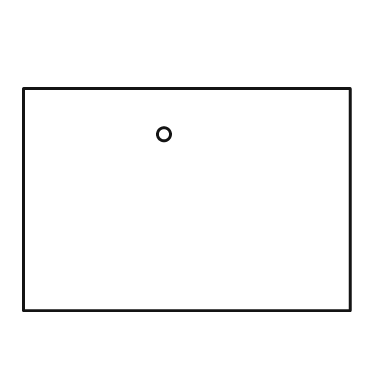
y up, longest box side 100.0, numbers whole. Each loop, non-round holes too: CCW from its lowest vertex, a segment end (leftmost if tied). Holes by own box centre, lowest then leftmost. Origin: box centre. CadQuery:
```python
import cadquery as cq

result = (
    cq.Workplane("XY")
    .moveTo(-50.0, -34.0)
    .lineTo(50.0, -34.0)
    .lineTo(50.0, 34.0)
    .lineTo(-50.0, 34.0)
    .close()
    .moveTo(-7.0, 20.0)
    .circle(2.0)
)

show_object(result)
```